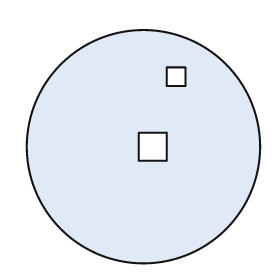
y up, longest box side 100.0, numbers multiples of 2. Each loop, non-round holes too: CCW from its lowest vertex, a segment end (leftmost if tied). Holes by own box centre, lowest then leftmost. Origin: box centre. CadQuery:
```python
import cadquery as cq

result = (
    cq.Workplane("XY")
    .moveTo(0.0, 0.0)
    .circle(50.0)
    .moveTo(-2.0, -6.0)
    .lineTo(10.0, -6.0)
    .lineTo(10.0, 6.0)
    .lineTo(-2.0, 6.0)
    .close()
    .moveTo(10.0, 26.0)
    .lineTo(18.0, 26.0)
    .lineTo(18.0, 34.0)
    .lineTo(10.0, 34.0)
    .close()
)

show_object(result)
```